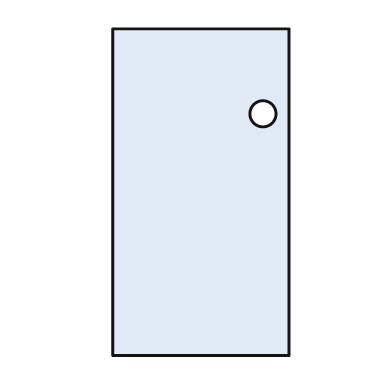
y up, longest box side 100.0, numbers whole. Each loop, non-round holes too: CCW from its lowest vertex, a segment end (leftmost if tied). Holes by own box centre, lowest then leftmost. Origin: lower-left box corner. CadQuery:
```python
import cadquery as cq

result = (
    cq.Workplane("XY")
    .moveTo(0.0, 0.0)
    .lineTo(54.0, 0.0)
    .lineTo(54.0, 100.0)
    .lineTo(0.0, 100.0)
    .close()
    .moveTo(46.0, 74.0)
    .circle(4.0)
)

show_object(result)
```